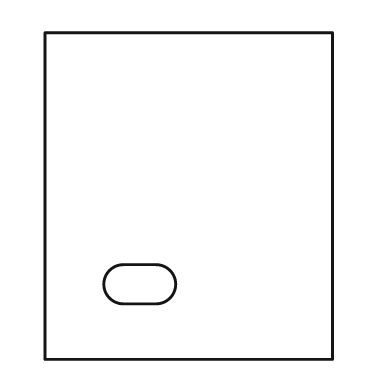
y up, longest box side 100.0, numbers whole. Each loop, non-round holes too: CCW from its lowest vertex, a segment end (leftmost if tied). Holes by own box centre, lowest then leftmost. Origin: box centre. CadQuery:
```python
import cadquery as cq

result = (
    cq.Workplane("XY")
    .moveTo(-44.0, -50.0)
    .lineTo(44.0, -50.0)
    .lineTo(44.0, 50.0)
    .lineTo(-44.0, 50.0)
    .close()
    .moveTo(-20.0, -33.0)
    .lineTo(-10.0, -33.0)
    .threePointArc((-4.0, -27.0), (-10.0, -21.0))
    .lineTo(-20.0, -21.0)
    .threePointArc((-26.0, -27.0), (-20.0, -33.0))
    .close()
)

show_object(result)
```